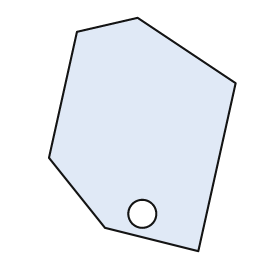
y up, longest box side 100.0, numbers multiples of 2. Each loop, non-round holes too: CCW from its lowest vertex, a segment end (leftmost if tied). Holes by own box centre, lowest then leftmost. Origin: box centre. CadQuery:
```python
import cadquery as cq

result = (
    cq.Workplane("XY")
    .moveTo(24.0, -50.0)
    .lineTo(40.0, 22.0)
    .lineTo(-2.0, 50.0)
    .lineTo(-28.0, 44.0)
    .lineTo(-40.0, -10.0)
    .lineTo(-16.0, -40.0)
    .close()
    .moveTo(0.0, -34.0)
    .circle(6.0)
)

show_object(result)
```